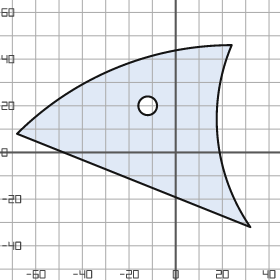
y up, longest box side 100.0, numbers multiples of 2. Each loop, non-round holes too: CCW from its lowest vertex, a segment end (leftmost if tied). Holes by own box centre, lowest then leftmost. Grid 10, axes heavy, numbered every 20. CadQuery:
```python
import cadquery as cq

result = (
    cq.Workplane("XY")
    .moveTo(32.0, -32.0)
    .threePointArc((18.0, 6.0), (24.0, 46.0))
    .threePointArc((-26.0, 36.0), (-68.0, 8.0))
    .close()
    .moveTo(-12.0, 20.0)
    .circle(4.0)
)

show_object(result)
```